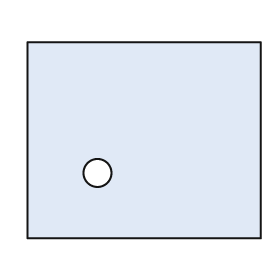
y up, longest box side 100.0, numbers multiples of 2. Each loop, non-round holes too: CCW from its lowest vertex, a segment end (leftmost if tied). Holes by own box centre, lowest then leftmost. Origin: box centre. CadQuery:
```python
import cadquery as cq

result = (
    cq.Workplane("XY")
    .moveTo(-50.0, -42.0)
    .lineTo(50.0, -42.0)
    .lineTo(50.0, 42.0)
    .lineTo(-50.0, 42.0)
    .close()
    .moveTo(-20.0, -14.0)
    .circle(6.0)
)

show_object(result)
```